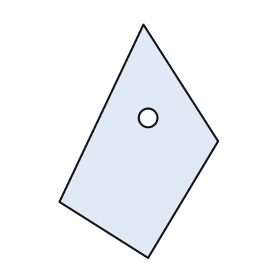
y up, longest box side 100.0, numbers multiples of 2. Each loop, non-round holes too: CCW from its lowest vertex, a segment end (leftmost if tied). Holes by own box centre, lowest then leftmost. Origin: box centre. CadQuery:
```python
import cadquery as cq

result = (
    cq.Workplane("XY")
    .moveTo(4.0, -50.0)
    .lineTo(34.0, 0.0)
    .lineTo(2.0, 50.0)
    .lineTo(-34.0, -26.0)
    .close()
    .moveTo(4.0, 10.0)
    .circle(4.0)
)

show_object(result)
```